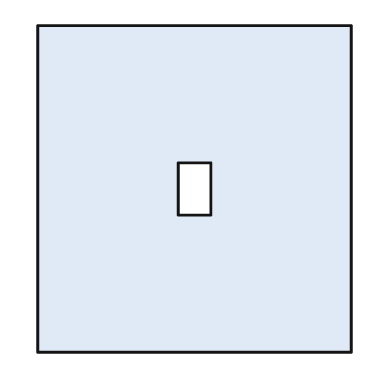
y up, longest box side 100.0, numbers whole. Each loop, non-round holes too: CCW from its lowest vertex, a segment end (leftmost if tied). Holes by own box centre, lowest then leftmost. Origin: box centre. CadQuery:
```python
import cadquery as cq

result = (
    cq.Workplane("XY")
    .moveTo(-48.0, -50.0)
    .lineTo(48.0, -50.0)
    .lineTo(48.0, 50.0)
    .lineTo(-48.0, 50.0)
    .close()
    .moveTo(-5.0, -8.0)
    .lineTo(5.0, -8.0)
    .lineTo(5.0, 8.0)
    .lineTo(-5.0, 8.0)
    .close()
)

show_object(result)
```